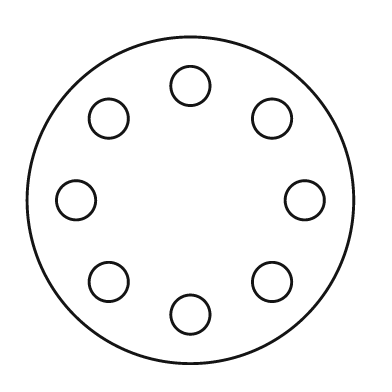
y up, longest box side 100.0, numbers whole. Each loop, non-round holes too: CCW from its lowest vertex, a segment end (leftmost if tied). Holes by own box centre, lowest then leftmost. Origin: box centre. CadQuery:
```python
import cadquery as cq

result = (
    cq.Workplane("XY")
    .moveTo(0.0, 0.0)
    .circle(50.0)
    .moveTo(0.0, -35.0)
    .circle(6.0)
    .moveTo(-25.0, -25.0)
    .circle(6.0)
    .moveTo(25.0, -25.0)
    .circle(6.0)
    .moveTo(-35.0, 0.0)
    .circle(6.0)
    .moveTo(35.0, 0.0)
    .circle(6.0)
    .moveTo(-25.0, 25.0)
    .circle(6.0)
    .moveTo(25.0, 25.0)
    .circle(6.0)
    .moveTo(0.0, 35.0)
    .circle(6.0)
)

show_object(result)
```